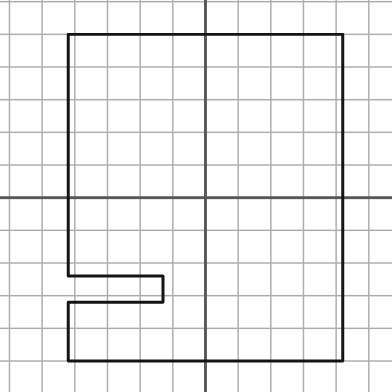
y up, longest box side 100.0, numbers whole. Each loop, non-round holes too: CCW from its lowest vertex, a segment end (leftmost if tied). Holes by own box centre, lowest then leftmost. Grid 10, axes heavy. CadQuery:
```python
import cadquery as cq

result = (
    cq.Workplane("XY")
    .moveTo(-42.0, -50.0)
    .lineTo(42.0, -50.0)
    .lineTo(42.0, 50.0)
    .lineTo(-42.0, 50.0)
    .lineTo(-42.0, -24.0)
    .lineTo(-13.0, -24.0)
    .lineTo(-13.0, -32.0)
    .lineTo(-42.0, -32.0)
    .close()
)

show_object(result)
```